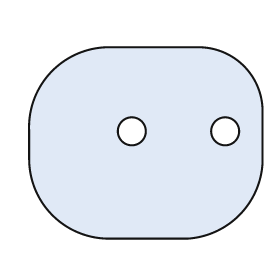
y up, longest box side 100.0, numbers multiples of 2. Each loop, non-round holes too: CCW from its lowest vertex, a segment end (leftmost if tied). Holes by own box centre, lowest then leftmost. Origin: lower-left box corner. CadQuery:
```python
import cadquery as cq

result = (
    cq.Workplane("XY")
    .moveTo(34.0, 0.0)
    .lineTo(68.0, 0.0)
    .threePointArc((90.0, 10.0), (100.0, 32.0))
    .lineTo(100.0, 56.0)
    .threePointArc((92.0, 74.0), (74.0, 82.0))
    .lineTo(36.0, 82.0)
    .threePointArc((10.0, 72.0), (0.0, 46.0))
    .lineTo(0.0, 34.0)
    .threePointArc((10.0, 10.0), (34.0, 0.0))
    .close()
    .moveTo(44.0, 46.0)
    .circle(6.0)
    .moveTo(84.0, 46.0)
    .circle(6.0)
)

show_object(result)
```